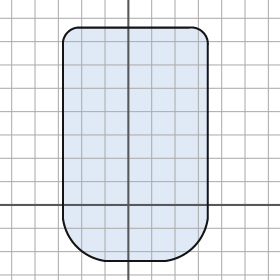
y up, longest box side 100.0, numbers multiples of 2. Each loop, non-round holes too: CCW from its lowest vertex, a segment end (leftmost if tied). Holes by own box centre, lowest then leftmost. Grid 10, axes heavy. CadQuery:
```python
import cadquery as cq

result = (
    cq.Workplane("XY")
    .moveTo(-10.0, -24.0)
    .lineTo(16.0, -24.0)
    .threePointArc((28.0, -18.0), (34.0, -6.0))
    .lineTo(34.0, 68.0)
    .threePointArc((32.0, 74.0), (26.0, 76.0))
    .lineTo(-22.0, 76.0)
    .threePointArc((-26.0, 74.0), (-28.0, 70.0))
    .lineTo(-28.0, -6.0)
    .threePointArc((-22.0, -18.0), (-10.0, -24.0))
    .close()
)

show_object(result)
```